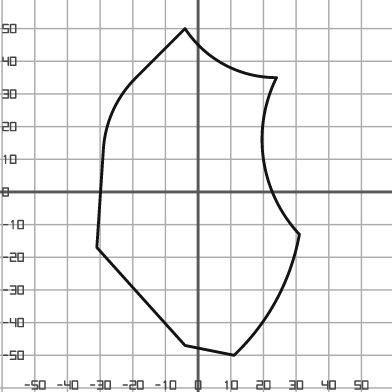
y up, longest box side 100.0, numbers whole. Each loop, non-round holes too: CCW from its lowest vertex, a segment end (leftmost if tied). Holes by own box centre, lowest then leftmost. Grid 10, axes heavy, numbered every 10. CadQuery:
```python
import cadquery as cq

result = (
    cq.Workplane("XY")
    .moveTo(11.0, -50.0)
    .threePointArc((24.0, -33.0), (31.0, -13.0))
    .threePointArc((20.0, 10.0), (24.0, 35.0))
    .threePointArc((8.0, 39.0), (-4.0, 50.0))
    .lineTo(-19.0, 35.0)
    .threePointArc((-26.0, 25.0), (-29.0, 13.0))
    .lineTo(-31.0, -17.0)
    .lineTo(-4.0, -47.0)
    .close()
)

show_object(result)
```